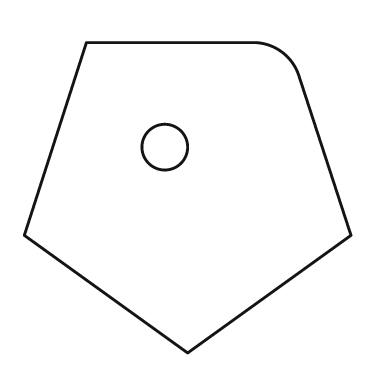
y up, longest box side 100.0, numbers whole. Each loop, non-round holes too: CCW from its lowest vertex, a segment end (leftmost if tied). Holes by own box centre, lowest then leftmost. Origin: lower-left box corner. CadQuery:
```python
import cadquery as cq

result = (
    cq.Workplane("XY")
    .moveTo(50.0, 0.0)
    .lineTo(100.0, 36.0)
    .lineTo(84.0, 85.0)
    .threePointArc((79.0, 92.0), (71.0, 95.0))
    .lineTo(19.0, 95.0)
    .lineTo(0.0, 36.0)
    .close()
    .moveTo(43.0, 63.0)
    .circle(7.0)
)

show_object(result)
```